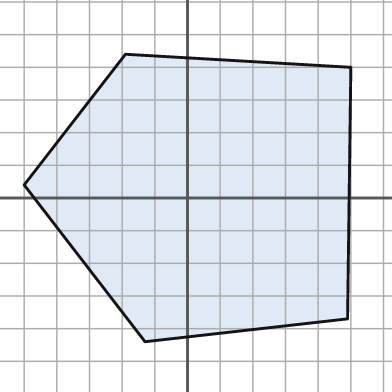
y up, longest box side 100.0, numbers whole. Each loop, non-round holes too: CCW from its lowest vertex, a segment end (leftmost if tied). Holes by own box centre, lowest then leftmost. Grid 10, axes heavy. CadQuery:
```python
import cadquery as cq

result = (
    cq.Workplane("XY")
    .moveTo(-13.0, -44.0)
    .lineTo(49.0, -37.0)
    .lineTo(50.0, 40.0)
    .lineTo(-19.0, 44.0)
    .lineTo(-50.0, 4.0)
    .close()
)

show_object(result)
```